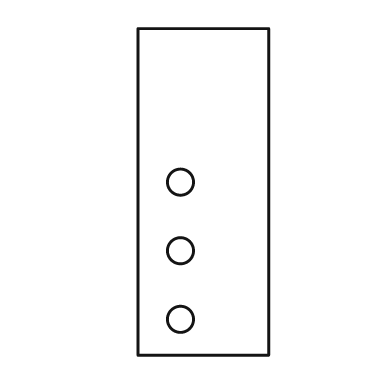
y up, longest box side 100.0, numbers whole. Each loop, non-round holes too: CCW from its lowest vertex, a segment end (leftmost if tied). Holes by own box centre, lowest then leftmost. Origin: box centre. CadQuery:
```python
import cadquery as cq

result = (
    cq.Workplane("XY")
    .moveTo(-20.0, -50.0)
    .lineTo(20.0, -50.0)
    .lineTo(20.0, 50.0)
    .lineTo(-20.0, 50.0)
    .close()
    .moveTo(-7.0, -39.0)
    .circle(4.0)
    .moveTo(-7.0, -18.0)
    .circle(4.0)
    .moveTo(-7.0, 3.0)
    .circle(4.0)
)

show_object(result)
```